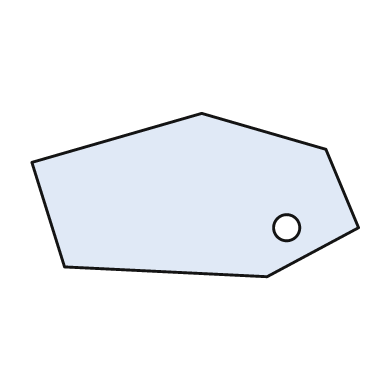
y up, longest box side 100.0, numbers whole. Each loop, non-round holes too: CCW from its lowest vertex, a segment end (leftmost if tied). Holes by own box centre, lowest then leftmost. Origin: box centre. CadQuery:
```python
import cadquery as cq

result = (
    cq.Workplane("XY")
    .moveTo(22.0, -25.0)
    .lineTo(50.0, -10.0)
    .lineTo(40.0, 14.0)
    .lineTo(2.0, 25.0)
    .lineTo(-50.0, 10.0)
    .lineTo(-40.0, -22.0)
    .close()
    .moveTo(28.0, -10.0)
    .circle(4.0)
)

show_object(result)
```